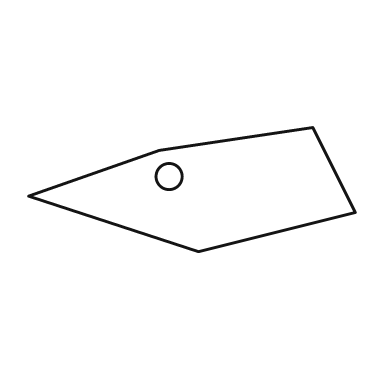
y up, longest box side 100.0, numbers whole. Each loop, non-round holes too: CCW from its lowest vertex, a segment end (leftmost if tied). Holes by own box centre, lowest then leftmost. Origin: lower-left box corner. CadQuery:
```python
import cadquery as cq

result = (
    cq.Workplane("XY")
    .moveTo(52.0, 0.0)
    .lineTo(100.0, 12.0)
    .lineTo(87.0, 38.0)
    .lineTo(40.0, 31.0)
    .lineTo(0.0, 17.0)
    .close()
    .moveTo(43.0, 23.0)
    .circle(4.0)
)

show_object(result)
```